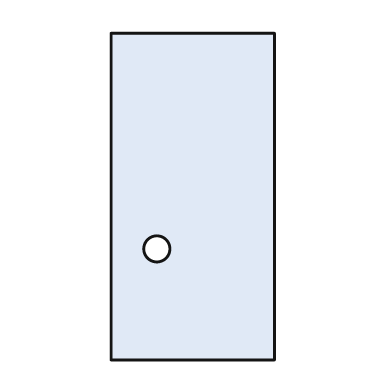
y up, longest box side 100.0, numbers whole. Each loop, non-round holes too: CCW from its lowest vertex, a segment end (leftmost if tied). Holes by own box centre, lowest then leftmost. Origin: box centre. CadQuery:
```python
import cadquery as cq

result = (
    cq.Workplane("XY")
    .moveTo(-25.0, -50.0)
    .lineTo(25.0, -50.0)
    .lineTo(25.0, 50.0)
    .lineTo(-25.0, 50.0)
    .close()
    .moveTo(-11.0, -16.0)
    .circle(4.0)
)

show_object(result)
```